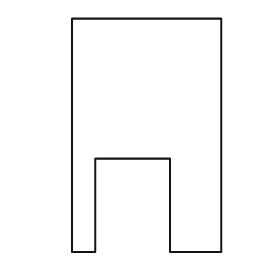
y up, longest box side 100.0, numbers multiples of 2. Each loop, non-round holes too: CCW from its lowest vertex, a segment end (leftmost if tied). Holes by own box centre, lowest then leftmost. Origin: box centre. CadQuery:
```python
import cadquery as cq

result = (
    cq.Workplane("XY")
    .moveTo(-32.0, -50.0)
    .lineTo(-22.0, -50.0)
    .lineTo(-22.0, -10.0)
    .lineTo(10.0, -10.0)
    .lineTo(10.0, -50.0)
    .lineTo(32.0, -50.0)
    .lineTo(32.0, 50.0)
    .lineTo(-32.0, 50.0)
    .close()
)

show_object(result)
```